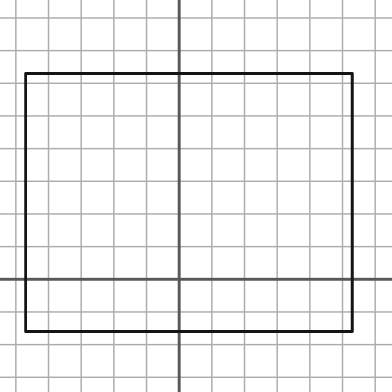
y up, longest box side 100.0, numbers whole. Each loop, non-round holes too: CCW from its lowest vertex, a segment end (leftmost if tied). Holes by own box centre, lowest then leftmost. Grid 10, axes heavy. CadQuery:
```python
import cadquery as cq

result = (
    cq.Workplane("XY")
    .moveTo(-47.0, -16.0)
    .lineTo(53.0, -16.0)
    .lineTo(53.0, 63.0)
    .lineTo(-47.0, 63.0)
    .close()
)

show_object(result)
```